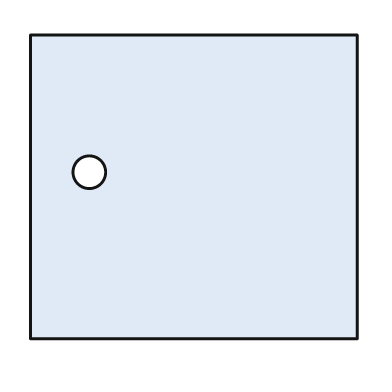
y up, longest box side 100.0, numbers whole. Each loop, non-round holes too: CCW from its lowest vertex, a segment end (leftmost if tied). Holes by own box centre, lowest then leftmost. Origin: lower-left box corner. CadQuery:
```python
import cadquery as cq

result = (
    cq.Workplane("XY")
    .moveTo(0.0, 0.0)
    .lineTo(100.0, 0.0)
    .lineTo(100.0, 93.0)
    .lineTo(0.0, 93.0)
    .close()
    .moveTo(18.0, 51.0)
    .circle(5.0)
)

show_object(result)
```